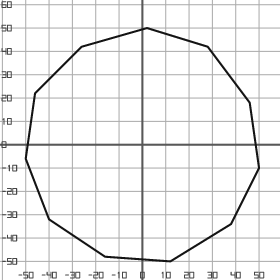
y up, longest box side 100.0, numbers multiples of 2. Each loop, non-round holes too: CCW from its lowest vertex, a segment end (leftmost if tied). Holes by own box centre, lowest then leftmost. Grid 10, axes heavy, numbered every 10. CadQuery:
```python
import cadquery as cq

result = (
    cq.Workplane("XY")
    .moveTo(12.0, -50.0)
    .lineTo(38.0, -34.0)
    .lineTo(50.0, -10.0)
    .lineTo(46.0, 18.0)
    .lineTo(28.0, 42.0)
    .lineTo(2.0, 50.0)
    .lineTo(-26.0, 42.0)
    .lineTo(-46.0, 22.0)
    .lineTo(-50.0, -6.0)
    .lineTo(-40.0, -32.0)
    .lineTo(-16.0, -48.0)
    .close()
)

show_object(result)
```